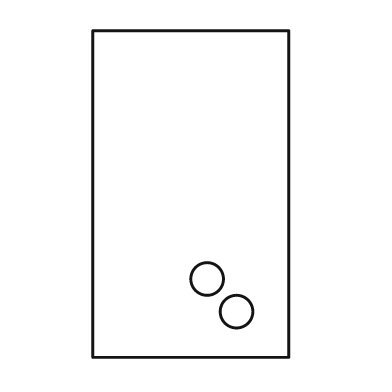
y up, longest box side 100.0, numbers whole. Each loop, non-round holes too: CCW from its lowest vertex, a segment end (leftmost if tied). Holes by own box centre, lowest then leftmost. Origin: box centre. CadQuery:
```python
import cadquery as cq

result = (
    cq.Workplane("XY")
    .moveTo(-30.0, -50.0)
    .lineTo(30.0, -50.0)
    .lineTo(30.0, 50.0)
    .lineTo(-30.0, 50.0)
    .close()
    .moveTo(14.0, -36.0)
    .circle(5.0)
    .moveTo(5.0, -26.0)
    .circle(5.0)
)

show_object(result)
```